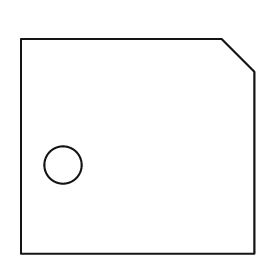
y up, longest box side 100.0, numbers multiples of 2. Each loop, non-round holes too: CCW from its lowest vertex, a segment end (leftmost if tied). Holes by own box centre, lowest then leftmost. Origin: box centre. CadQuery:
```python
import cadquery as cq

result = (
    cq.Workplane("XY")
    .moveTo(-50.0, -46.0)
    .lineTo(50.0, -46.0)
    .lineTo(50.0, 32.0)
    .lineTo(36.0, 46.0)
    .lineTo(-50.0, 46.0)
    .close()
    .moveTo(-32.0, -8.0)
    .circle(8.0)
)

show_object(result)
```